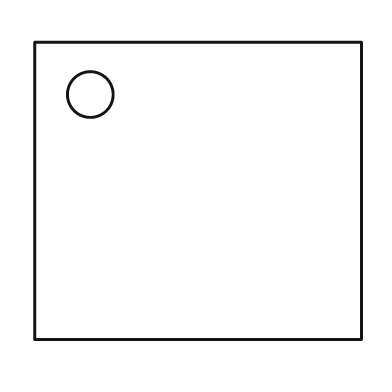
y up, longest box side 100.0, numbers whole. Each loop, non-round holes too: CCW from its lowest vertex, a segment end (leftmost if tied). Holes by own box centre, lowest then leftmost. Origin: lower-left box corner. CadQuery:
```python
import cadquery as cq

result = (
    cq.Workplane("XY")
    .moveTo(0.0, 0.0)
    .lineTo(100.0, 0.0)
    .lineTo(100.0, 91.0)
    .lineTo(0.0, 91.0)
    .close()
    .moveTo(17.0, 75.0)
    .circle(7.0)
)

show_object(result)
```